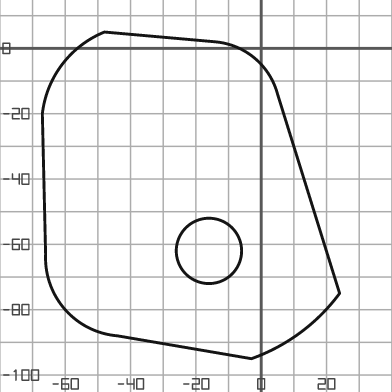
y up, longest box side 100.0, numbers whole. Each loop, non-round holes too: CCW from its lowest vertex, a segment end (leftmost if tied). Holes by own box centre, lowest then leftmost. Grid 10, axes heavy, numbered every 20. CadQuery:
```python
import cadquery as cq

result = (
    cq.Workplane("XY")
    .moveTo(-3.0, -95.0)
    .threePointArc((12.0, -87.0), (24.0, -75.0))
    .lineTo(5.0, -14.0)
    .threePointArc((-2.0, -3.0), (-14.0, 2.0))
    .lineTo(-48.0, 5.0)
    .threePointArc((-61.0, -5.0), (-67.0, -20.0))
    .lineTo(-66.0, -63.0)
    .threePointArc((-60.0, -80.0), (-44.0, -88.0))
    .close()
    .moveTo(-16.0, -62.0)
    .circle(10.0)
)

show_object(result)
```